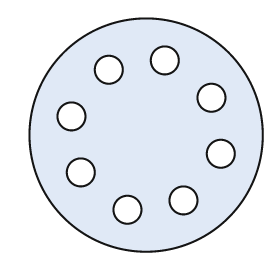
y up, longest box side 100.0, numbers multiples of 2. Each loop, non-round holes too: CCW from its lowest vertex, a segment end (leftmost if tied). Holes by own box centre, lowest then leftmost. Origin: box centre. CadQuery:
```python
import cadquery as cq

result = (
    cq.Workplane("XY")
    .moveTo(0.0, 0.0)
    .circle(50.0)
    .moveTo(-8.0, -32.0)
    .circle(6.0)
    .moveTo(16.0, -28.0)
    .circle(6.0)
    .moveTo(-28.0, -16.0)
    .circle(6.0)
    .moveTo(32.0, -8.0)
    .circle(6.0)
    .moveTo(-32.0, 8.0)
    .circle(6.0)
    .moveTo(28.0, 16.0)
    .circle(6.0)
    .moveTo(-16.0, 28.0)
    .circle(6.0)
    .moveTo(8.0, 32.0)
    .circle(6.0)
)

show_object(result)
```